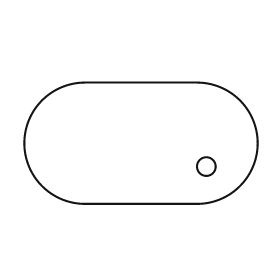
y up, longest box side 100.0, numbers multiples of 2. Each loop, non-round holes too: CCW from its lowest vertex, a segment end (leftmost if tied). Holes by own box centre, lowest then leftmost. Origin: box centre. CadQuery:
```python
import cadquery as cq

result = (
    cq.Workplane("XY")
    .moveTo(-24.0, -26.0)
    .lineTo(24.0, -26.0)
    .threePointArc((50.0, 0.0), (24.0, 26.0))
    .lineTo(-24.0, 26.0)
    .threePointArc((-50.0, 0.0), (-24.0, -26.0))
    .close()
    .moveTo(28.0, -10.0)
    .circle(4.0)
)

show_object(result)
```